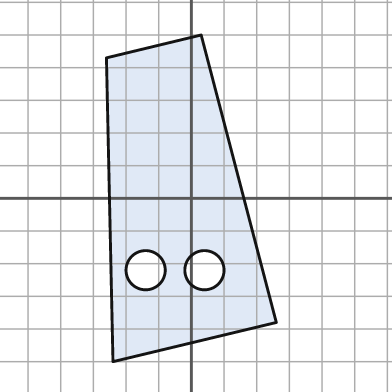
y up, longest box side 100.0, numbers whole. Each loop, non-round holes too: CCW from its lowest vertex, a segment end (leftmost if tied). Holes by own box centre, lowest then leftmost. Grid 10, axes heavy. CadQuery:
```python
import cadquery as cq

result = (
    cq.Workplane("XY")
    .moveTo(-24.0, -50.0)
    .lineTo(26.0, -38.0)
    .lineTo(3.0, 50.0)
    .lineTo(-26.0, 43.0)
    .close()
    .moveTo(-14.0, -22.0)
    .circle(6.0)
    .moveTo(4.0, -22.0)
    .circle(6.0)
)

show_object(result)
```